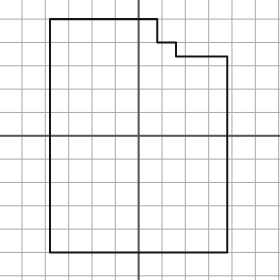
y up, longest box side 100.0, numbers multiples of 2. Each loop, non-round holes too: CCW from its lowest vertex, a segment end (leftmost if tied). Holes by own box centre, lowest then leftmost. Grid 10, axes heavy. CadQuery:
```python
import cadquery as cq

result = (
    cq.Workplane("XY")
    .moveTo(-38.0, -50.0)
    .lineTo(38.0, -50.0)
    .lineTo(38.0, 34.0)
    .lineTo(16.0, 34.0)
    .lineTo(16.0, 40.0)
    .lineTo(8.0, 40.0)
    .lineTo(8.0, 50.0)
    .lineTo(-38.0, 50.0)
    .close()
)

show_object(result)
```